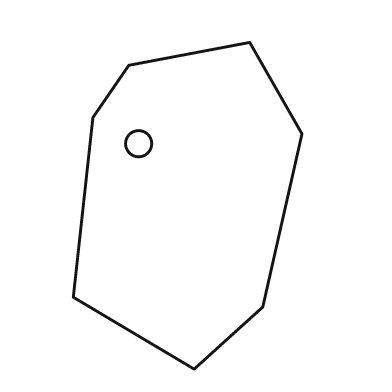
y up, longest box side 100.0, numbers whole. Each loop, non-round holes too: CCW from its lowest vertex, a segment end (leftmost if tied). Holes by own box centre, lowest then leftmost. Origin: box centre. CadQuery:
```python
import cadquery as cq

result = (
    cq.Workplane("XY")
    .moveTo(2.0, -50.0)
    .lineTo(23.0, -31.0)
    .lineTo(35.0, 22.0)
    .lineTo(19.0, 50.0)
    .lineTo(-18.0, 43.0)
    .lineTo(-29.0, 27.0)
    .lineTo(-35.0, -28.0)
    .close()
    .moveTo(-15.0, 19.0)
    .circle(4.0)
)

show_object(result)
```